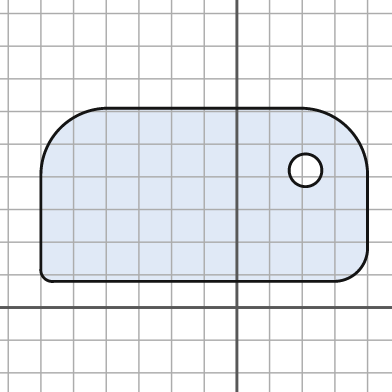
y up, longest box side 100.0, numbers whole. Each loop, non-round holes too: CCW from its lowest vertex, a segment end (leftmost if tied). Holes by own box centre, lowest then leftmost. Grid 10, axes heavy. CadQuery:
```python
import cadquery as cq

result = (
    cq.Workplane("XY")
    .moveTo(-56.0, 8.0)
    .lineTo(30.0, 8.0)
    .threePointArc((37.0, 11.0), (40.0, 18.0))
    .lineTo(40.0, 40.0)
    .threePointArc((34.0, 55.0), (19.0, 61.0))
    .lineTo(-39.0, 61.0)
    .threePointArc((-54.0, 55.0), (-60.0, 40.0))
    .lineTo(-60.0, 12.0)
    .threePointArc((-59.0, 9.0), (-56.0, 8.0))
    .close()
    .moveTo(21.0, 42.0)
    .circle(5.0)
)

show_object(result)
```